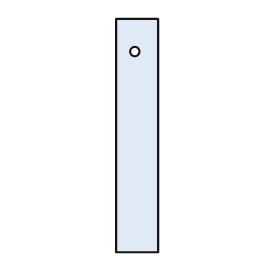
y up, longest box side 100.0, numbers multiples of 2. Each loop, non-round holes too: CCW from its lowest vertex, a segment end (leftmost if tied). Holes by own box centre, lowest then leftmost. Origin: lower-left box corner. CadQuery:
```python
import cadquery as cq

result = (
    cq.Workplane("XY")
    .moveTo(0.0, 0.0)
    .lineTo(18.0, 0.0)
    .lineTo(18.0, 100.0)
    .lineTo(0.0, 100.0)
    .close()
    .moveTo(8.0, 86.0)
    .circle(2.0)
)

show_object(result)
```